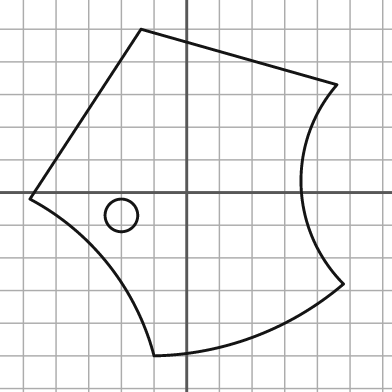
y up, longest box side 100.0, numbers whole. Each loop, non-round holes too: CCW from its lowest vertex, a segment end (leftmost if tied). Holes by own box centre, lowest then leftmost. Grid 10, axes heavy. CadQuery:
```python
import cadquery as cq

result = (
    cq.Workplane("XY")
    .moveTo(-10.0, -50.0)
    .threePointArc((21.0, -44.0), (48.0, -28.0))
    .threePointArc((35.0, 2.0), (46.0, 33.0))
    .lineTo(-14.0, 50.0)
    .lineTo(-48.0, -2.0)
    .threePointArc((-24.0, -22.0), (-10.0, -50.0))
    .close()
    .moveTo(-20.0, -7.0)
    .circle(5.0)
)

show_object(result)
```